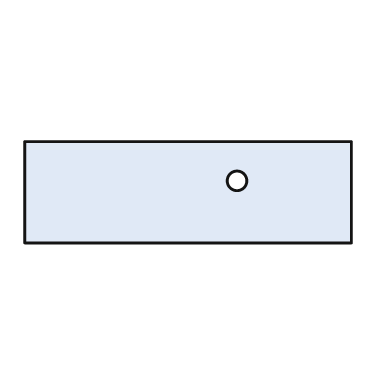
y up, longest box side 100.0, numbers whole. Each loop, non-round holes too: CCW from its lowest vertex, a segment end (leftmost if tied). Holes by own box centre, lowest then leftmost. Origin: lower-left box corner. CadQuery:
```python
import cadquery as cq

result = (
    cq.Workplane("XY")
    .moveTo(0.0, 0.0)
    .lineTo(100.0, 0.0)
    .lineTo(100.0, 31.0)
    .lineTo(0.0, 31.0)
    .close()
    .moveTo(65.0, 19.0)
    .circle(3.0)
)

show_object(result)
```